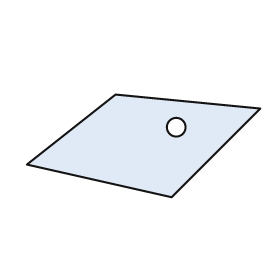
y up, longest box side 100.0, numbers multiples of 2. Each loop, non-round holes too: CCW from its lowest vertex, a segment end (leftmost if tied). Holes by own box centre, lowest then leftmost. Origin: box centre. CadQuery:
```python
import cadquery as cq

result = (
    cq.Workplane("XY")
    .moveTo(12.0, -22.0)
    .lineTo(50.0, 16.0)
    .lineTo(-12.0, 22.0)
    .lineTo(-50.0, -8.0)
    .close()
    .moveTo(14.0, 8.0)
    .circle(4.0)
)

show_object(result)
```